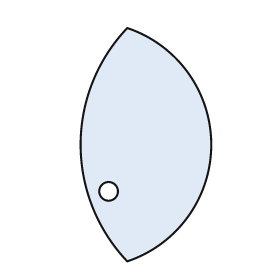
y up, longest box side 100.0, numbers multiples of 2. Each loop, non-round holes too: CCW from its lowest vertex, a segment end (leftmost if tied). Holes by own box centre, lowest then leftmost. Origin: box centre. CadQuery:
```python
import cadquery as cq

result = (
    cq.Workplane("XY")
    .moveTo(-8.0, -50.0)
    .threePointArc((28.0, 0.0), (-8.0, 50.0))
    .threePointArc((-28.0, 0.0), (-8.0, -50.0))
    .close()
    .moveTo(-16.0, -20.0)
    .circle(4.0)
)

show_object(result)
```